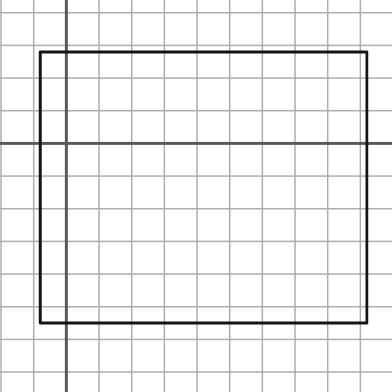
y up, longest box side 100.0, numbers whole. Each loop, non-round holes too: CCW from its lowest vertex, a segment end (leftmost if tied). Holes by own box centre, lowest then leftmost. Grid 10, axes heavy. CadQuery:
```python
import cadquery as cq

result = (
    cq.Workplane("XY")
    .moveTo(-8.0, -55.0)
    .lineTo(92.0, -55.0)
    .lineTo(92.0, 28.0)
    .lineTo(-8.0, 28.0)
    .close()
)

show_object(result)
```